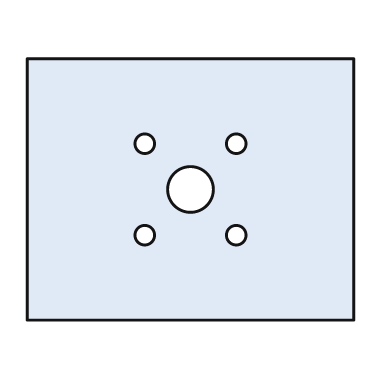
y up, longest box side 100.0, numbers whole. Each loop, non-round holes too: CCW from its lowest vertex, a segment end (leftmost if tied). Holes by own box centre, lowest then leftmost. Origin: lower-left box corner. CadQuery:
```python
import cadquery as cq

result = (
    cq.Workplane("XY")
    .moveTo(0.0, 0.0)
    .lineTo(100.0, 0.0)
    .lineTo(100.0, 80.0)
    .lineTo(0.0, 80.0)
    .close()
    .moveTo(36.0, 26.0)
    .circle(3.0)
    .moveTo(64.0, 26.0)
    .circle(3.0)
    .moveTo(50.0, 40.0)
    .circle(7.0)
    .moveTo(36.0, 54.0)
    .circle(3.0)
    .moveTo(64.0, 54.0)
    .circle(3.0)
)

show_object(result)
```